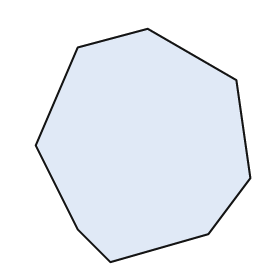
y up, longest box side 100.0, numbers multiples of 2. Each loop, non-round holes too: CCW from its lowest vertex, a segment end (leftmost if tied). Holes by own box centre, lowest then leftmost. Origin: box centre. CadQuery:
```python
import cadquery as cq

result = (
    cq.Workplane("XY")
    .moveTo(-14.0, -50.0)
    .lineTo(28.0, -38.0)
    .lineTo(46.0, -14.0)
    .lineTo(40.0, 28.0)
    .lineTo(2.0, 50.0)
    .lineTo(-28.0, 42.0)
    .lineTo(-46.0, 0.0)
    .lineTo(-28.0, -36.0)
    .close()
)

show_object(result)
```